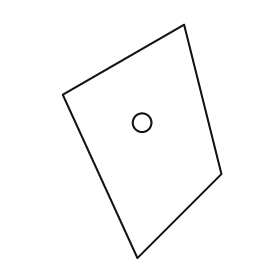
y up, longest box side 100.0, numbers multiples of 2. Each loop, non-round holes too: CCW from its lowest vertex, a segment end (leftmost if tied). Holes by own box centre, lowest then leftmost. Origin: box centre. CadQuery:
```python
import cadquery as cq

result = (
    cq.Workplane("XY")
    .moveTo(-2.0, -50.0)
    .lineTo(34.0, -14.0)
    .lineTo(18.0, 50.0)
    .lineTo(-34.0, 20.0)
    .close()
    .moveTo(0.0, 8.0)
    .circle(4.0)
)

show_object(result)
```